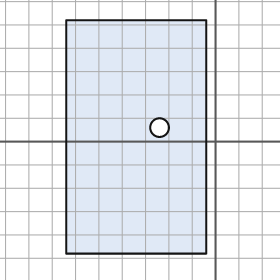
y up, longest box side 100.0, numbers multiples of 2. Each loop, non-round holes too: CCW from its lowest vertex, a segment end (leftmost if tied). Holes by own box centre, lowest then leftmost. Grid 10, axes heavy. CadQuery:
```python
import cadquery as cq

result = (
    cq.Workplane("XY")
    .moveTo(-64.0, -48.0)
    .lineTo(-4.0, -48.0)
    .lineTo(-4.0, 52.0)
    .lineTo(-64.0, 52.0)
    .close()
    .moveTo(-24.0, 6.0)
    .circle(4.0)
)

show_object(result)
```